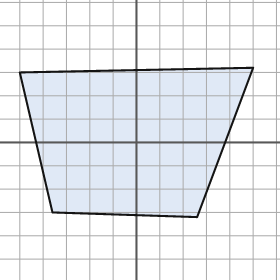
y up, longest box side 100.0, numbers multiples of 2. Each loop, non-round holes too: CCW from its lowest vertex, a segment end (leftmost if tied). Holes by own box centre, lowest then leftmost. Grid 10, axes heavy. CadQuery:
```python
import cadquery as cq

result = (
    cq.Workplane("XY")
    .moveTo(26.0, -32.0)
    .lineTo(50.0, 32.0)
    .lineTo(-50.0, 30.0)
    .lineTo(-36.0, -30.0)
    .close()
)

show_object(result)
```